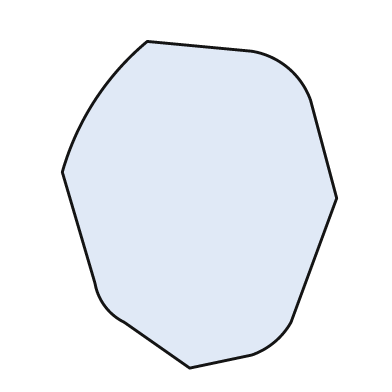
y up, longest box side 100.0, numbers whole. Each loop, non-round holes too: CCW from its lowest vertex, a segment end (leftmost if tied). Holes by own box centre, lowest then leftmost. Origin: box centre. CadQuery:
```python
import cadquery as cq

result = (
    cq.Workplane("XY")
    .moveTo(-3.0, -50.0)
    .lineTo(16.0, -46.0)
    .threePointArc((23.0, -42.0), (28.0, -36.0))
    .lineTo(42.0, 2.0)
    .lineTo(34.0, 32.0)
    .threePointArc((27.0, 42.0), (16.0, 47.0))
    .lineTo(-16.0, 50.0)
    .threePointArc((-32.0, 32.0), (-42.0, 10.0))
    .lineTo(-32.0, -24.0)
    .threePointArc((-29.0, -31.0), (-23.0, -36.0))
    .close()
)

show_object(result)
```